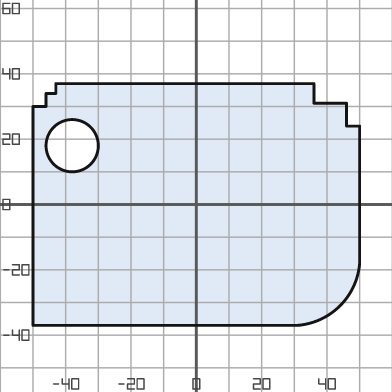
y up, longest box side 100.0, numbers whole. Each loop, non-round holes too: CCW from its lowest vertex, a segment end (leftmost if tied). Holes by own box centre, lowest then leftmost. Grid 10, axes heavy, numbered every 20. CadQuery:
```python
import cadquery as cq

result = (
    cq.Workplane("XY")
    .moveTo(-50.0, -37.0)
    .lineTo(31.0, -37.0)
    .threePointArc((44.0, -31.0), (50.0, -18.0))
    .lineTo(50.0, 24.0)
    .lineTo(46.0, 24.0)
    .lineTo(46.0, 31.0)
    .lineTo(36.0, 31.0)
    .lineTo(36.0, 37.0)
    .lineTo(-43.0, 37.0)
    .lineTo(-43.0, 34.0)
    .lineTo(-46.0, 34.0)
    .lineTo(-46.0, 30.0)
    .lineTo(-50.0, 30.0)
    .close()
    .moveTo(-38.0, 18.0)
    .circle(8.0)
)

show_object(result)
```